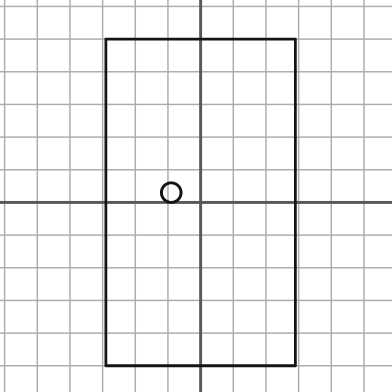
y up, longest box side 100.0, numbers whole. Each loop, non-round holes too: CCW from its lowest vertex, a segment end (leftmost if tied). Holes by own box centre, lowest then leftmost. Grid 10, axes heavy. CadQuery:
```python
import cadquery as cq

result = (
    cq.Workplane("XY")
    .moveTo(-29.0, -50.0)
    .lineTo(29.0, -50.0)
    .lineTo(29.0, 50.0)
    .lineTo(-29.0, 50.0)
    .close()
    .moveTo(-9.0, 3.0)
    .circle(3.0)
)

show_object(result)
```